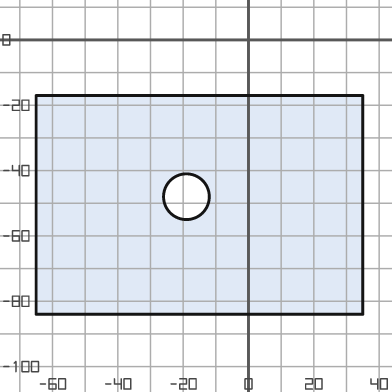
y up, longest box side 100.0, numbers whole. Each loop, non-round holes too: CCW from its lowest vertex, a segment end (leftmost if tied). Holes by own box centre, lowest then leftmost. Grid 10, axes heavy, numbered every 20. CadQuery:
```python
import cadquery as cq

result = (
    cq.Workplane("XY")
    .moveTo(-65.0, -84.0)
    .lineTo(35.0, -84.0)
    .lineTo(35.0, -17.0)
    .lineTo(-65.0, -17.0)
    .close()
    .moveTo(-19.0, -48.0)
    .circle(7.0)
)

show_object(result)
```